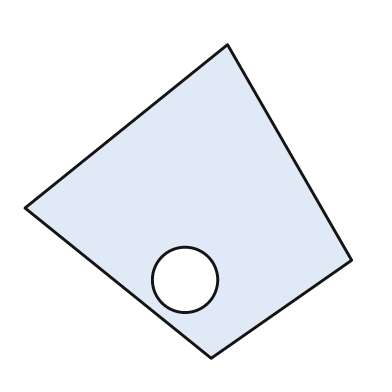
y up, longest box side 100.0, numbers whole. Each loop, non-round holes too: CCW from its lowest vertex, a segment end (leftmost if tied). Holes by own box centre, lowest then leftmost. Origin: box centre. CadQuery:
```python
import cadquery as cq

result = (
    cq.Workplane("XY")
    .moveTo(7.0, -48.0)
    .lineTo(50.0, -18.0)
    .lineTo(12.0, 48.0)
    .lineTo(-50.0, -2.0)
    .close()
    .moveTo(-1.0, -24.0)
    .circle(10.0)
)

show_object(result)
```